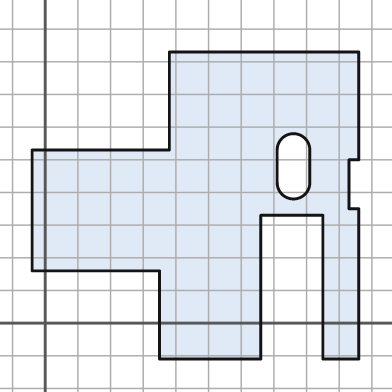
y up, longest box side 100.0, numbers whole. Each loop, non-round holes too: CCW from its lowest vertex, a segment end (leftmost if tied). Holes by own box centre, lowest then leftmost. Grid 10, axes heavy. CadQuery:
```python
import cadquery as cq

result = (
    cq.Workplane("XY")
    .moveTo(35.0, -11.0)
    .lineTo(66.0, -11.0)
    .lineTo(66.0, 33.0)
    .lineTo(85.0, 33.0)
    .lineTo(85.0, -11.0)
    .lineTo(96.0, -11.0)
    .lineTo(96.0, 35.0)
    .lineTo(93.0, 35.0)
    .lineTo(93.0, 50.0)
    .lineTo(96.0, 50.0)
    .lineTo(96.0, 83.0)
    .lineTo(38.0, 83.0)
    .lineTo(38.0, 53.0)
    .lineTo(-4.0, 53.0)
    .lineTo(-4.0, 16.0)
    .lineTo(35.0, 16.0)
    .close()
    .moveTo(71.0, 43.0)
    .threePointArc((76.0, 38.0), (81.0, 43.0))
    .lineTo(81.0, 53.0)
    .threePointArc((76.0, 58.0), (71.0, 53.0))
    .close()
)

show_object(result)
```